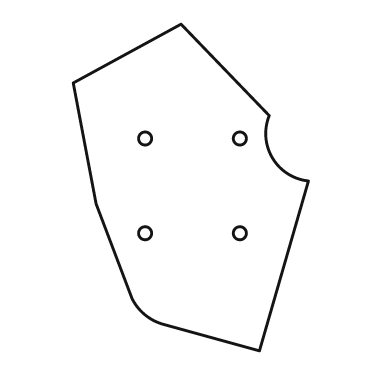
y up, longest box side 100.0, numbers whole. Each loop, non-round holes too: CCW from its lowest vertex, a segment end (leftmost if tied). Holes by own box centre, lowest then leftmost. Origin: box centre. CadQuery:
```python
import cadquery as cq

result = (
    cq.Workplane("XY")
    .moveTo(21.0, -50.0)
    .lineTo(36.0, 2.0)
    .threePointArc((25.0, 9.0), (24.0, 22.0))
    .lineTo(-3.0, 50.0)
    .lineTo(-36.0, 32.0)
    .lineTo(-29.0, -5.0)
    .lineTo(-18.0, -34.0)
    .threePointArc((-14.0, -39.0), (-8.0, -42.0))
    .close()
    .moveTo(-14.0, -14.0)
    .circle(2.0)
    .moveTo(15.0, -14.0)
    .circle(2.0)
    .moveTo(-14.0, 15.0)
    .circle(2.0)
    .moveTo(15.0, 15.0)
    .circle(2.0)
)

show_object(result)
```